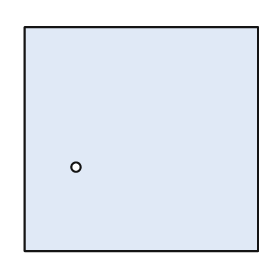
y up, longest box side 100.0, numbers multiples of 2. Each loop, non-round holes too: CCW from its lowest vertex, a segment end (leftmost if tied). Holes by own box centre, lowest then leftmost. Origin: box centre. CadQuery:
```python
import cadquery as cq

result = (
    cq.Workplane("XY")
    .moveTo(-50.0, -48.0)
    .lineTo(50.0, -48.0)
    .lineTo(50.0, 48.0)
    .lineTo(-50.0, 48.0)
    .close()
    .moveTo(-28.0, -12.0)
    .circle(2.0)
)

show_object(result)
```